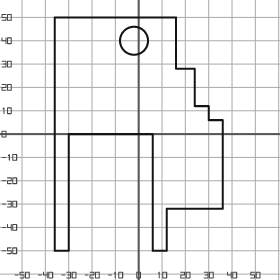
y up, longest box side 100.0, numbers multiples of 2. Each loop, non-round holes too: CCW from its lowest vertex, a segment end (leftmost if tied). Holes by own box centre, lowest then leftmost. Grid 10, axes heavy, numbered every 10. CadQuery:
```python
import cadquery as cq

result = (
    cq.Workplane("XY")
    .moveTo(-36.0, -50.0)
    .lineTo(-30.0, -50.0)
    .lineTo(-30.0, 0.0)
    .lineTo(6.0, 0.0)
    .lineTo(6.0, -50.0)
    .lineTo(12.0, -50.0)
    .lineTo(12.0, -32.0)
    .lineTo(36.0, -32.0)
    .lineTo(36.0, 6.0)
    .lineTo(30.0, 6.0)
    .lineTo(30.0, 12.0)
    .lineTo(24.0, 12.0)
    .lineTo(24.0, 28.0)
    .lineTo(16.0, 28.0)
    .lineTo(16.0, 50.0)
    .lineTo(-36.0, 50.0)
    .close()
    .moveTo(-2.0, 40.0)
    .circle(6.0)
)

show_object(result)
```